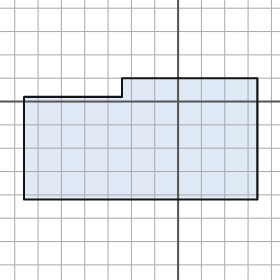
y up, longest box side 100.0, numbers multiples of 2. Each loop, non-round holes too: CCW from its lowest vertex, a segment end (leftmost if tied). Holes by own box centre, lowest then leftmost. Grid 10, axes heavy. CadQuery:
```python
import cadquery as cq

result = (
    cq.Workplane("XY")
    .moveTo(-66.0, -42.0)
    .lineTo(34.0, -42.0)
    .lineTo(34.0, 10.0)
    .lineTo(-24.0, 10.0)
    .lineTo(-24.0, 2.0)
    .lineTo(-66.0, 2.0)
    .close()
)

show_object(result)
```